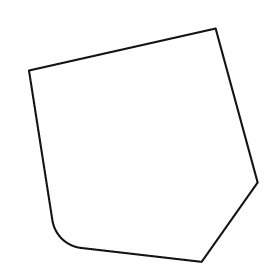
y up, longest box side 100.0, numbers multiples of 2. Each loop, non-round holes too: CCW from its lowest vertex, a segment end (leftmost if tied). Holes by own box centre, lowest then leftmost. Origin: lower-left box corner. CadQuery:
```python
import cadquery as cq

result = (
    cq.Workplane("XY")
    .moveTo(74.0, 0.0)
    .lineTo(98.0, 34.0)
    .lineTo(80.0, 100.0)
    .lineTo(0.0, 82.0)
    .lineTo(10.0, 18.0)
    .threePointArc((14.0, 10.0), (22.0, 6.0))
    .close()
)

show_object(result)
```